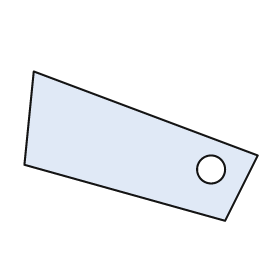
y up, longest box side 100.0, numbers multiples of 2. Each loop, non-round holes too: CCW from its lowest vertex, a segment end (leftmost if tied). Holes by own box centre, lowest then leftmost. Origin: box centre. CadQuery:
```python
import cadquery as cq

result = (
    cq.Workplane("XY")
    .moveTo(36.0, -32.0)
    .lineTo(50.0, -4.0)
    .lineTo(-46.0, 32.0)
    .lineTo(-50.0, -8.0)
    .close()
    .moveTo(30.0, -10.0)
    .circle(6.0)
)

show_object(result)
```